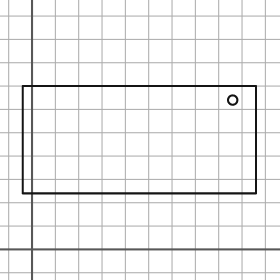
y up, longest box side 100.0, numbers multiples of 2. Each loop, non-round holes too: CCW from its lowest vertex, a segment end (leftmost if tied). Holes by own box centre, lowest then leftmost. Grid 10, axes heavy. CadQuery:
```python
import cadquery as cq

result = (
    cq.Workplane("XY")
    .moveTo(-4.0, 24.0)
    .lineTo(96.0, 24.0)
    .lineTo(96.0, 70.0)
    .lineTo(-4.0, 70.0)
    .close()
    .moveTo(86.0, 64.0)
    .circle(2.0)
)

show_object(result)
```